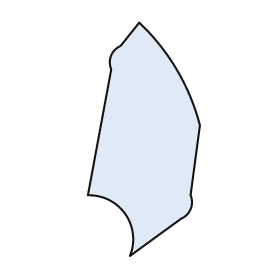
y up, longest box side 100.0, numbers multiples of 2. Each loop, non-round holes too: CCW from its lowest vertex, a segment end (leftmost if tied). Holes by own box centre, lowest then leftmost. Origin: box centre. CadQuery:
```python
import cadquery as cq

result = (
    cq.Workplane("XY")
    .moveTo(-6.0, -50.0)
    .lineTo(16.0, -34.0)
    .threePointArc((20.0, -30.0), (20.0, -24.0))
    .lineTo(24.0, 6.0)
    .threePointArc((14.0, 30.0), (-2.0, 50.0))
    .lineTo(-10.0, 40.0)
    .threePointArc((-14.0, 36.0), (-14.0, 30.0))
    .lineTo(-24.0, -24.0)
    .threePointArc((-8.0, -32.0), (-6.0, -50.0))
    .close()
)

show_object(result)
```